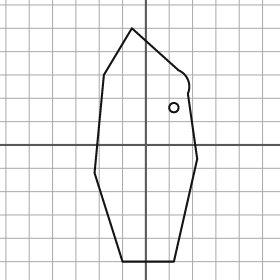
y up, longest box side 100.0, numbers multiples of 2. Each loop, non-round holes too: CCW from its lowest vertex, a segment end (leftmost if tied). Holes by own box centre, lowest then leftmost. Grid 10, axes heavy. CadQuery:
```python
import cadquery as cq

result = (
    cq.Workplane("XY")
    .moveTo(-10.0, -50.0)
    .lineTo(12.0, -50.0)
    .lineTo(22.0, -6.0)
    .lineTo(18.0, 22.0)
    .threePointArc((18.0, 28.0), (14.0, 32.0))
    .lineTo(-6.0, 50.0)
    .lineTo(-18.0, 30.0)
    .lineTo(-22.0, -12.0)
    .close()
    .moveTo(12.0, 16.0)
    .circle(2.0)
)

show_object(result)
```